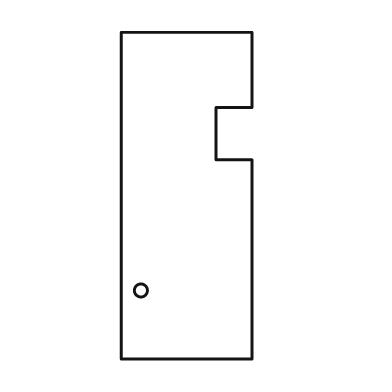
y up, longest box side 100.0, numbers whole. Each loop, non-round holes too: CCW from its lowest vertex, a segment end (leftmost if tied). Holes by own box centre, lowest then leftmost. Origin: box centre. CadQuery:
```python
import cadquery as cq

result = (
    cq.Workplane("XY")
    .moveTo(-20.0, -50.0)
    .lineTo(20.0, -50.0)
    .lineTo(20.0, 11.0)
    .lineTo(9.0, 11.0)
    .lineTo(9.0, 27.0)
    .lineTo(20.0, 27.0)
    .lineTo(20.0, 50.0)
    .lineTo(-20.0, 50.0)
    .close()
    .moveTo(-14.0, -29.0)
    .circle(2.0)
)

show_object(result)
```